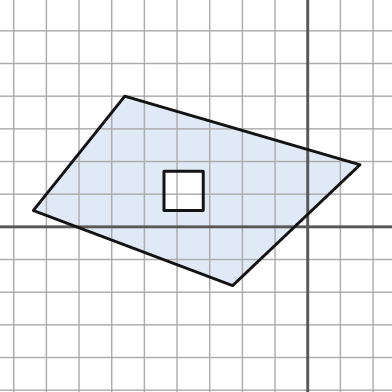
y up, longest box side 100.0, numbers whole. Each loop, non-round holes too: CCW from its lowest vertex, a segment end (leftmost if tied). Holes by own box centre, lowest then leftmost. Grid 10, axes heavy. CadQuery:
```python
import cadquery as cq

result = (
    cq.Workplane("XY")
    .moveTo(-23.0, -18.0)
    .lineTo(16.0, 19.0)
    .lineTo(-56.0, 40.0)
    .lineTo(-84.0, 5.0)
    .close()
    .moveTo(-44.0, 5.0)
    .lineTo(-32.0, 5.0)
    .lineTo(-32.0, 17.0)
    .lineTo(-44.0, 17.0)
    .close()
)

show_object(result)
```